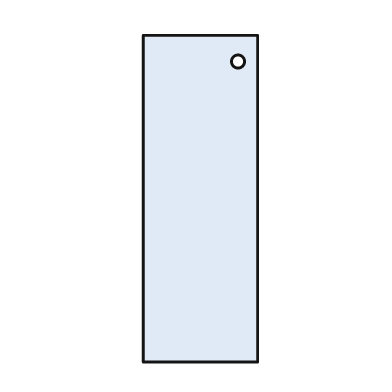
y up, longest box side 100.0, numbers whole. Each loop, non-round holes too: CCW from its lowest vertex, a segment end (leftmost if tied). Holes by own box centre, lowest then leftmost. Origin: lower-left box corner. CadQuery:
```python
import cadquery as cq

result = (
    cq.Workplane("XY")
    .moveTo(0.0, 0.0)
    .lineTo(35.0, 0.0)
    .lineTo(35.0, 100.0)
    .lineTo(0.0, 100.0)
    .close()
    .moveTo(29.0, 92.0)
    .circle(2.0)
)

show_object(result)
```